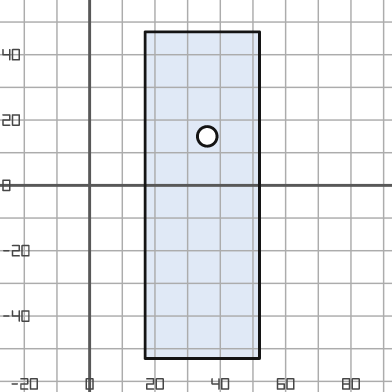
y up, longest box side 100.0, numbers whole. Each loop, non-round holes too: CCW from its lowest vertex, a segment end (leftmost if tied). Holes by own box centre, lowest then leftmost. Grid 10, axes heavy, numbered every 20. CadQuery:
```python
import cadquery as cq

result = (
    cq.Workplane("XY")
    .moveTo(17.0, -53.0)
    .lineTo(52.0, -53.0)
    .lineTo(52.0, 47.0)
    .lineTo(17.0, 47.0)
    .close()
    .moveTo(36.0, 15.0)
    .circle(3.0)
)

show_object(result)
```